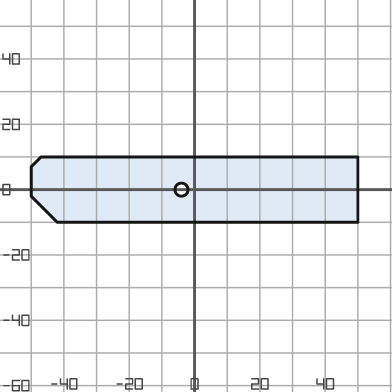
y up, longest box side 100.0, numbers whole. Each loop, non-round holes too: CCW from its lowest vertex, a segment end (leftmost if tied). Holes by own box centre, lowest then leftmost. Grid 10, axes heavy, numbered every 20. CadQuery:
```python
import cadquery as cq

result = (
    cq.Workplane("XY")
    .moveTo(-42.0, -10.0)
    .lineTo(50.0, -10.0)
    .lineTo(50.0, 10.0)
    .lineTo(-47.0, 10.0)
    .lineTo(-50.0, 7.0)
    .lineTo(-50.0, -2.0)
    .close()
    .moveTo(-4.0, 0.0)
    .circle(2.0)
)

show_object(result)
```